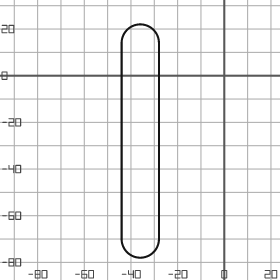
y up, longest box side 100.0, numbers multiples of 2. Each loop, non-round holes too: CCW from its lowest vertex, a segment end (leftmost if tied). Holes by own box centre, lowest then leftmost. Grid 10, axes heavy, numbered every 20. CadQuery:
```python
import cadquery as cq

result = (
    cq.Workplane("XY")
    .moveTo(-44.0, -70.0)
    .threePointArc((-36.0, -78.0), (-28.0, -70.0))
    .lineTo(-28.0, 14.0)
    .threePointArc((-36.0, 22.0), (-44.0, 14.0))
    .close()
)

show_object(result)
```